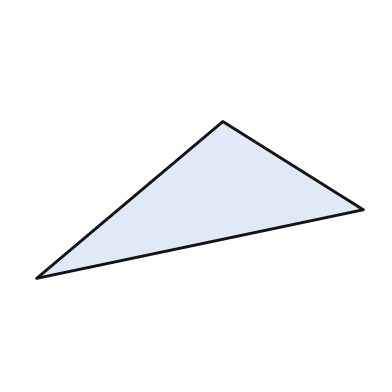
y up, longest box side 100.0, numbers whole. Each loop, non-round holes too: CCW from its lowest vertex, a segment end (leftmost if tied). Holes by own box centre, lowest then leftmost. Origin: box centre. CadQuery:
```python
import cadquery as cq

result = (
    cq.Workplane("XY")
    .moveTo(-50.0, -24.0)
    .lineTo(50.0, -3.0)
    .lineTo(7.0, 24.0)
    .close()
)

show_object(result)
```